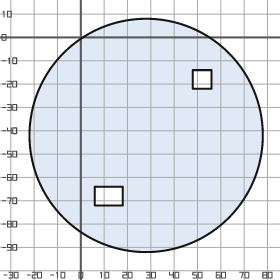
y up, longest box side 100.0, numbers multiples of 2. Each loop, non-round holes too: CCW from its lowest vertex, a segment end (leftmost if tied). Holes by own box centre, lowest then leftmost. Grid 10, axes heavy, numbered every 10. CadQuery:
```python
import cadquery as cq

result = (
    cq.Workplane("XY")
    .moveTo(28.0, -42.0)
    .circle(50.0)
    .moveTo(6.0, -72.0)
    .lineTo(18.0, -72.0)
    .lineTo(18.0, -64.0)
    .lineTo(6.0, -64.0)
    .close()
    .moveTo(48.0, -22.0)
    .lineTo(56.0, -22.0)
    .lineTo(56.0, -14.0)
    .lineTo(48.0, -14.0)
    .close()
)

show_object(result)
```